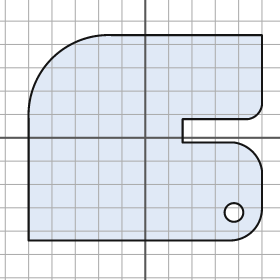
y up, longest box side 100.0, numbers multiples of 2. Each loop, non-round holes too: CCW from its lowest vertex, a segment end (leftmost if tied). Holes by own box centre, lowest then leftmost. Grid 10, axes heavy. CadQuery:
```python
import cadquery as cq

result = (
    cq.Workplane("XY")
    .moveTo(-50.0, -44.0)
    .lineTo(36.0, -44.0)
    .threePointArc((46.0, -40.0), (50.0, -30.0))
    .lineTo(50.0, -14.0)
    .threePointArc((46.0, -6.0), (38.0, -2.0))
    .lineTo(16.0, -2.0)
    .lineTo(16.0, 8.0)
    .lineTo(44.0, 8.0)
    .threePointArc((48.0, 10.0), (50.0, 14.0))
    .lineTo(50.0, 44.0)
    .lineTo(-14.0, 44.0)
    .threePointArc((-40.0, 34.0), (-50.0, 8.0))
    .close()
    .moveTo(38.0, -32.0)
    .circle(4.0)
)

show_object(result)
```